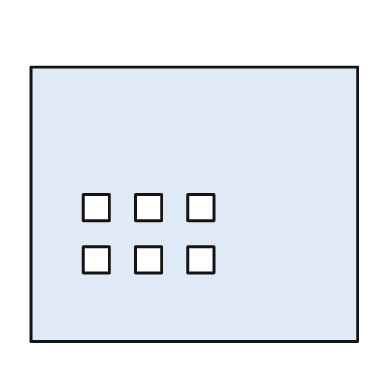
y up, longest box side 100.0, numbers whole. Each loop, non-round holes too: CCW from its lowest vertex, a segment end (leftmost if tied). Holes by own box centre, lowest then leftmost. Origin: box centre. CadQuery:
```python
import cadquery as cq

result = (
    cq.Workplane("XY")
    .moveTo(-50.0, -42.0)
    .lineTo(50.0, -42.0)
    .lineTo(50.0, 42.0)
    .lineTo(-50.0, 42.0)
    .close()
    .moveTo(-34.0, -21.0)
    .lineTo(-26.0, -21.0)
    .lineTo(-26.0, -13.0)
    .lineTo(-34.0, -13.0)
    .close()
    .moveTo(-18.0, -21.0)
    .lineTo(-10.0, -21.0)
    .lineTo(-10.0, -13.0)
    .lineTo(-18.0, -13.0)
    .close()
    .moveTo(-2.0, -21.0)
    .lineTo(6.0, -21.0)
    .lineTo(6.0, -13.0)
    .lineTo(-2.0, -13.0)
    .close()
    .moveTo(-34.0, -5.0)
    .lineTo(-26.0, -5.0)
    .lineTo(-26.0, 3.0)
    .lineTo(-34.0, 3.0)
    .close()
    .moveTo(-18.0, -5.0)
    .lineTo(-10.0, -5.0)
    .lineTo(-10.0, 3.0)
    .lineTo(-18.0, 3.0)
    .close()
    .moveTo(-2.0, -5.0)
    .lineTo(6.0, -5.0)
    .lineTo(6.0, 3.0)
    .lineTo(-2.0, 3.0)
    .close()
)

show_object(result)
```